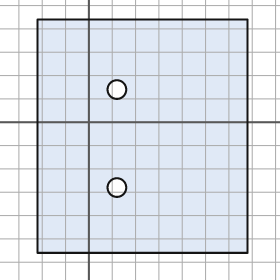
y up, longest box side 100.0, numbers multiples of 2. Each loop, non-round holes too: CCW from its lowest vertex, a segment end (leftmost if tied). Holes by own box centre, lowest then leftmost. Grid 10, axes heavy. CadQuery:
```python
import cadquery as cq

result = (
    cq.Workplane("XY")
    .moveTo(-22.0, -56.0)
    .lineTo(68.0, -56.0)
    .lineTo(68.0, 44.0)
    .lineTo(-22.0, 44.0)
    .close()
    .moveTo(12.0, -28.0)
    .circle(4.0)
    .moveTo(12.0, 14.0)
    .circle(4.0)
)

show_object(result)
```